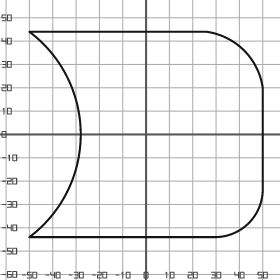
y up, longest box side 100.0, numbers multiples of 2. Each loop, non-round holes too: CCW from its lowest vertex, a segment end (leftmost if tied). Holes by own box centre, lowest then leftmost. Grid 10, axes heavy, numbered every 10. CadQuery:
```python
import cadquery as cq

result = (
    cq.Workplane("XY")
    .moveTo(-50.0, -44.0)
    .lineTo(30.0, -44.0)
    .threePointArc((44.0, -38.0), (50.0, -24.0))
    .lineTo(50.0, 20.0)
    .threePointArc((42.0, 36.0), (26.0, 44.0))
    .lineTo(-50.0, 44.0)
    .threePointArc((-28.0, 0.0), (-50.0, -44.0))
    .close()
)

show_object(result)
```